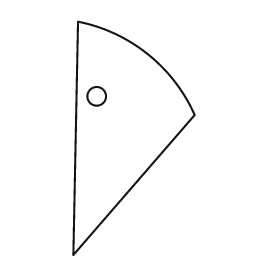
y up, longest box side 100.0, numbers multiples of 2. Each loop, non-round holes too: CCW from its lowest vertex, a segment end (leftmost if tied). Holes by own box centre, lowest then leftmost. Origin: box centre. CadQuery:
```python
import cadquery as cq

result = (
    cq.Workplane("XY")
    .moveTo(-26.0, -50.0)
    .lineTo(26.0, 10.0)
    .threePointArc((6.0, 36.0), (-24.0, 50.0))
    .close()
    .moveTo(-16.0, 18.0)
    .circle(4.0)
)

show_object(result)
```